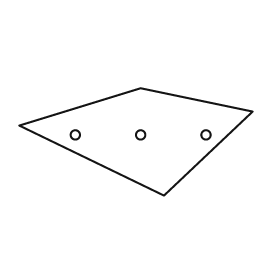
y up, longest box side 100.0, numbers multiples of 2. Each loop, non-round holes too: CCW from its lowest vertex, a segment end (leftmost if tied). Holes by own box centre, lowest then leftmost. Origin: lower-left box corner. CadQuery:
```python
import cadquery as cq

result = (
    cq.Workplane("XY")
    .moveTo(62.0, 0.0)
    .lineTo(100.0, 36.0)
    .lineTo(52.0, 46.0)
    .lineTo(0.0, 30.0)
    .close()
    .moveTo(24.0, 26.0)
    .circle(2.0)
    .moveTo(52.0, 26.0)
    .circle(2.0)
    .moveTo(80.0, 26.0)
    .circle(2.0)
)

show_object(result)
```